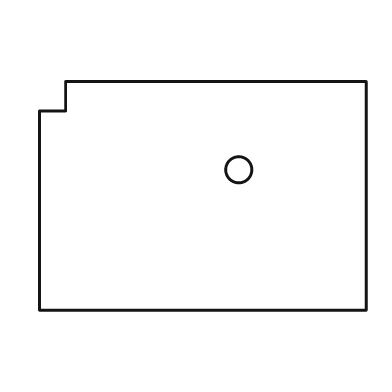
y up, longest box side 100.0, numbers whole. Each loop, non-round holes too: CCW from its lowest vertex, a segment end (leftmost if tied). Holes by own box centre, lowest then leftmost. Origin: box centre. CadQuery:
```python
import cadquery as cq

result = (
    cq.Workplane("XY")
    .moveTo(-50.0, -35.0)
    .lineTo(50.0, -35.0)
    .lineTo(50.0, 35.0)
    .lineTo(-42.0, 35.0)
    .lineTo(-42.0, 26.0)
    .lineTo(-50.0, 26.0)
    .close()
    .moveTo(11.0, 8.0)
    .circle(4.0)
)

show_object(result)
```